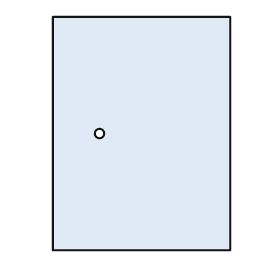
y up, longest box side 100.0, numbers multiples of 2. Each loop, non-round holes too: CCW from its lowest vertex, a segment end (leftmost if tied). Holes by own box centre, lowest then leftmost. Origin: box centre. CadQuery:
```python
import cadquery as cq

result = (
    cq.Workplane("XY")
    .moveTo(-38.0, -50.0)
    .lineTo(38.0, -50.0)
    .lineTo(38.0, 50.0)
    .lineTo(-38.0, 50.0)
    .close()
    .moveTo(-18.0, 0.0)
    .circle(2.0)
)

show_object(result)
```